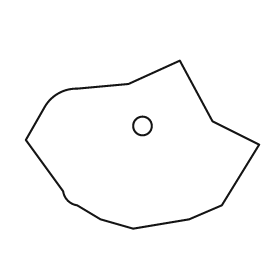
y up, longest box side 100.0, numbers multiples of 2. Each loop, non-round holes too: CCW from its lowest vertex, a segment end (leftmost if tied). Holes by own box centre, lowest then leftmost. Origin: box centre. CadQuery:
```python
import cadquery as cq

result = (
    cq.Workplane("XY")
    .moveTo(-4.0, -36.0)
    .lineTo(20.0, -32.0)
    .lineTo(34.0, -26.0)
    .lineTo(50.0, 0.0)
    .lineTo(30.0, 10.0)
    .lineTo(16.0, 36.0)
    .lineTo(-6.0, 26.0)
    .lineTo(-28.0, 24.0)
    .threePointArc((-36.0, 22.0), (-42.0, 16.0))
    .lineTo(-50.0, 2.0)
    .lineTo(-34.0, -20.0)
    .threePointArc((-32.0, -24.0), (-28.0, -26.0))
    .lineTo(-18.0, -32.0)
    .close()
    .moveTo(0.0, 8.0)
    .circle(4.0)
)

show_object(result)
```